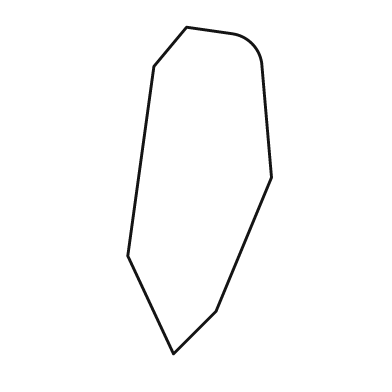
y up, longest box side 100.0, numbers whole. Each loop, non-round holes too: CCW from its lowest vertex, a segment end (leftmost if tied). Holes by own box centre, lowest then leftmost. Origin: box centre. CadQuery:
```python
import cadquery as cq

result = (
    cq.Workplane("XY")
    .moveTo(-8.0, -50.0)
    .lineTo(5.0, -37.0)
    .lineTo(22.0, 4.0)
    .lineTo(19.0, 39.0)
    .threePointArc((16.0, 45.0), (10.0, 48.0))
    .lineTo(-4.0, 50.0)
    .lineTo(-14.0, 38.0)
    .lineTo(-22.0, -20.0)
    .close()
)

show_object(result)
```